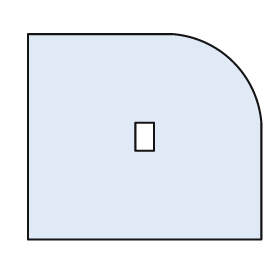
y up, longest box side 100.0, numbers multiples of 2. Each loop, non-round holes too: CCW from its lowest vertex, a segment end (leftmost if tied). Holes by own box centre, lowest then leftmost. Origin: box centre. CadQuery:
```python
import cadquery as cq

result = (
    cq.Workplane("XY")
    .moveTo(-50.0, -44.0)
    .lineTo(50.0, -44.0)
    .lineTo(50.0, 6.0)
    .threePointArc((38.0, 32.0), (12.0, 44.0))
    .lineTo(-50.0, 44.0)
    .close()
    .moveTo(-4.0, -6.0)
    .lineTo(4.0, -6.0)
    .lineTo(4.0, 6.0)
    .lineTo(-4.0, 6.0)
    .close()
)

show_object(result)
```